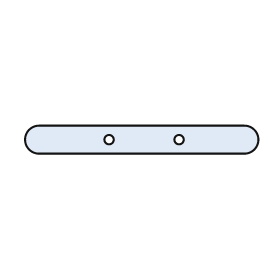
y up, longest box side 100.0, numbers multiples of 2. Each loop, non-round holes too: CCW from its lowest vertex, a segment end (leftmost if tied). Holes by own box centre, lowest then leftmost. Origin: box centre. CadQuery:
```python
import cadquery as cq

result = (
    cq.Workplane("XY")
    .moveTo(-44.0, -6.0)
    .lineTo(44.0, -6.0)
    .threePointArc((50.0, 0.0), (44.0, 6.0))
    .lineTo(-44.0, 6.0)
    .threePointArc((-50.0, 0.0), (-44.0, -6.0))
    .close()
    .moveTo(-14.0, 0.0)
    .circle(2.0)
    .moveTo(16.0, 0.0)
    .circle(2.0)
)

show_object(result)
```